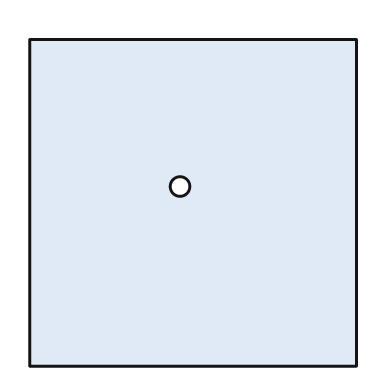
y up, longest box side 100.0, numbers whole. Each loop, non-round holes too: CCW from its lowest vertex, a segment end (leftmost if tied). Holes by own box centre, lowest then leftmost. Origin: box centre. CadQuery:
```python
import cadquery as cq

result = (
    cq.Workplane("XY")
    .moveTo(-50.0, -50.0)
    .lineTo(50.0, -50.0)
    .lineTo(50.0, 50.0)
    .lineTo(-50.0, 50.0)
    .close()
    .moveTo(-4.0, 5.0)
    .circle(3.0)
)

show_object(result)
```